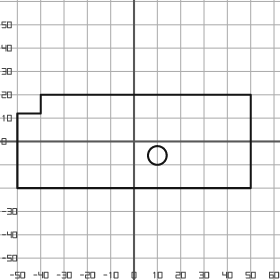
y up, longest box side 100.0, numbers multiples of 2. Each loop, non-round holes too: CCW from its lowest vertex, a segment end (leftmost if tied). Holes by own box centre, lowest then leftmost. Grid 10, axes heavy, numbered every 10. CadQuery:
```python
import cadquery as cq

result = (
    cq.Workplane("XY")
    .moveTo(-50.0, -20.0)
    .lineTo(50.0, -20.0)
    .lineTo(50.0, 20.0)
    .lineTo(-40.0, 20.0)
    .lineTo(-40.0, 12.0)
    .lineTo(-50.0, 12.0)
    .close()
    .moveTo(10.0, -6.0)
    .circle(4.0)
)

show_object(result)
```